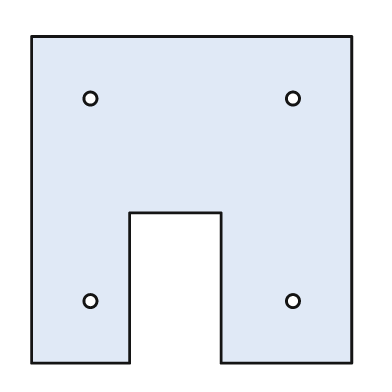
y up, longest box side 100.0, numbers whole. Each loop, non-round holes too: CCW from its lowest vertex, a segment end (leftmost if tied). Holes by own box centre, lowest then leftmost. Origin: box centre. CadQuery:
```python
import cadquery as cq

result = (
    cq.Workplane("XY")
    .moveTo(-49.0, -50.0)
    .lineTo(-19.0, -50.0)
    .lineTo(-19.0, -4.0)
    .lineTo(9.0, -4.0)
    .lineTo(9.0, -50.0)
    .lineTo(49.0, -50.0)
    .lineTo(49.0, 50.0)
    .lineTo(-49.0, 50.0)
    .close()
    .moveTo(-31.0, -31.0)
    .circle(2.0)
    .moveTo(31.0, -31.0)
    .circle(2.0)
    .moveTo(-31.0, 31.0)
    .circle(2.0)
    .moveTo(31.0, 31.0)
    .circle(2.0)
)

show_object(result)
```